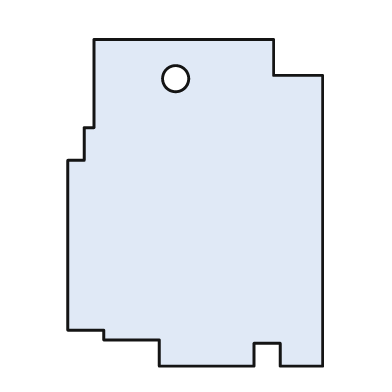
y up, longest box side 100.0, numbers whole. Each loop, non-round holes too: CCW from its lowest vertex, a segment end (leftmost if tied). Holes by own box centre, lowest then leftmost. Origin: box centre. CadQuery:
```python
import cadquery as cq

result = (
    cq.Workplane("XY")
    .moveTo(-11.0, -50.0)
    .lineTo(18.0, -50.0)
    .lineTo(18.0, -43.0)
    .lineTo(26.0, -43.0)
    .lineTo(26.0, -50.0)
    .lineTo(39.0, -50.0)
    .lineTo(39.0, 39.0)
    .lineTo(24.0, 39.0)
    .lineTo(24.0, 50.0)
    .lineTo(-31.0, 50.0)
    .lineTo(-31.0, 23.0)
    .lineTo(-34.0, 23.0)
    .lineTo(-34.0, 13.0)
    .lineTo(-39.0, 13.0)
    .lineTo(-39.0, -39.0)
    .lineTo(-28.0, -39.0)
    .lineTo(-28.0, -42.0)
    .lineTo(-11.0, -42.0)
    .close()
    .moveTo(-6.0, 38.0)
    .circle(4.0)
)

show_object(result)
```